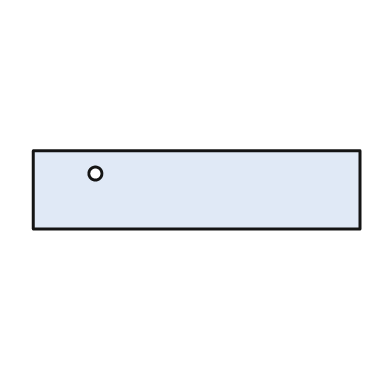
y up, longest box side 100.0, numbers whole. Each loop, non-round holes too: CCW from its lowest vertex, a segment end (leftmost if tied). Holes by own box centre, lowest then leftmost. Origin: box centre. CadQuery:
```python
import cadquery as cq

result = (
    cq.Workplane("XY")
    .moveTo(-50.0, -12.0)
    .lineTo(50.0, -12.0)
    .lineTo(50.0, 12.0)
    .lineTo(-50.0, 12.0)
    .close()
    .moveTo(-31.0, 5.0)
    .circle(2.0)
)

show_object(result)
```